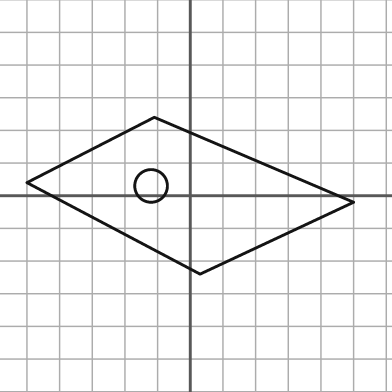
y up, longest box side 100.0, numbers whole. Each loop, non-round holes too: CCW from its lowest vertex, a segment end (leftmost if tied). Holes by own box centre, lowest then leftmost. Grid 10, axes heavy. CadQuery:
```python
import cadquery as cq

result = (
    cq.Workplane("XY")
    .moveTo(3.0, -24.0)
    .lineTo(50.0, -2.0)
    .lineTo(-11.0, 24.0)
    .lineTo(-50.0, 4.0)
    .close()
    .moveTo(-12.0, 3.0)
    .circle(5.0)
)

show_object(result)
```